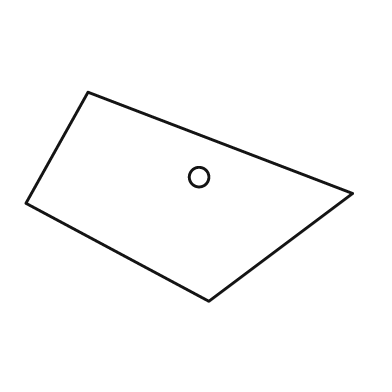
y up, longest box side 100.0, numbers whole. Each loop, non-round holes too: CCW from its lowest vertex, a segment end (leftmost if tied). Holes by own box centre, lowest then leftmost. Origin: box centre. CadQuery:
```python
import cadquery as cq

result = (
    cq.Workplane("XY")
    .moveTo(6.0, -32.0)
    .lineTo(50.0, 1.0)
    .lineTo(-31.0, 32.0)
    .lineTo(-50.0, -2.0)
    .close()
    .moveTo(3.0, 6.0)
    .circle(3.0)
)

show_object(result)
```